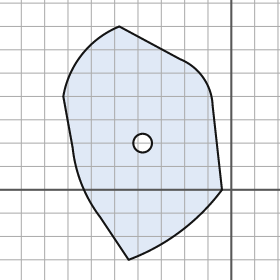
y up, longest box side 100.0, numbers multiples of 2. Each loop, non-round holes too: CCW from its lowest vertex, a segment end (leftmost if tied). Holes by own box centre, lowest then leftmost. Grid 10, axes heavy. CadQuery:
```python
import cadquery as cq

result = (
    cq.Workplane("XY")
    .moveTo(-44.0, -30.0)
    .threePointArc((-22.0, -18.0), (-4.0, 0.0))
    .lineTo(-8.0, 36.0)
    .threePointArc((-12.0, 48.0), (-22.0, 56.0))
    .lineTo(-48.0, 70.0)
    .threePointArc((-64.0, 58.0), (-72.0, 40.0))
    .lineTo(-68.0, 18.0)
    .threePointArc((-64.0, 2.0), (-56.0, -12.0))
    .close()
    .moveTo(-38.0, 20.0)
    .circle(4.0)
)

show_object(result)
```